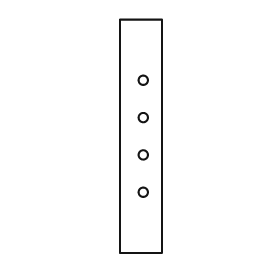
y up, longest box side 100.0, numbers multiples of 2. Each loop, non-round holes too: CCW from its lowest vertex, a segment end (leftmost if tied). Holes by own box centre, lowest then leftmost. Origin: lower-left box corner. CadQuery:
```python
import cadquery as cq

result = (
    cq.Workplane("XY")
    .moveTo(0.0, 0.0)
    .lineTo(18.0, 0.0)
    .lineTo(18.0, 100.0)
    .lineTo(0.0, 100.0)
    .close()
    .moveTo(10.0, 26.0)
    .circle(2.0)
    .moveTo(10.0, 42.0)
    .circle(2.0)
    .moveTo(10.0, 58.0)
    .circle(2.0)
    .moveTo(10.0, 74.0)
    .circle(2.0)
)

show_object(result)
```